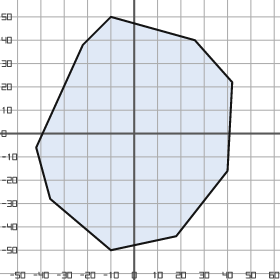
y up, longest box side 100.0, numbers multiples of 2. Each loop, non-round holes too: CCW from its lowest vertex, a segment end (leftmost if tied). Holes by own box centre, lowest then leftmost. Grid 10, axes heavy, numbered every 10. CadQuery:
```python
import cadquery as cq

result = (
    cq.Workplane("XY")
    .moveTo(-10.0, -50.0)
    .lineTo(18.0, -44.0)
    .lineTo(40.0, -16.0)
    .lineTo(42.0, 22.0)
    .lineTo(26.0, 40.0)
    .lineTo(-10.0, 50.0)
    .lineTo(-22.0, 38.0)
    .lineTo(-42.0, -6.0)
    .lineTo(-36.0, -28.0)
    .close()
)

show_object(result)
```